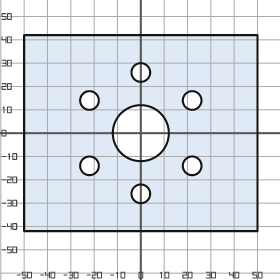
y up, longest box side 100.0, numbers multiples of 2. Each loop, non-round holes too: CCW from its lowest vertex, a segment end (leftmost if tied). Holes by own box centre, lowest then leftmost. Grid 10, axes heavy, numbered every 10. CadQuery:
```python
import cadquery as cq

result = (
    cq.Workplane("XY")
    .moveTo(-50.0, -42.0)
    .lineTo(50.0, -42.0)
    .lineTo(50.0, 42.0)
    .lineTo(-50.0, 42.0)
    .close()
    .moveTo(0.0, -26.0)
    .circle(4.0)
    .moveTo(-22.0, -14.0)
    .circle(4.0)
    .moveTo(22.0, -14.0)
    .circle(4.0)
    .moveTo(0.0, 0.0)
    .circle(12.0)
    .moveTo(-22.0, 14.0)
    .circle(4.0)
    .moveTo(22.0, 14.0)
    .circle(4.0)
    .moveTo(0.0, 26.0)
    .circle(4.0)
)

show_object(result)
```